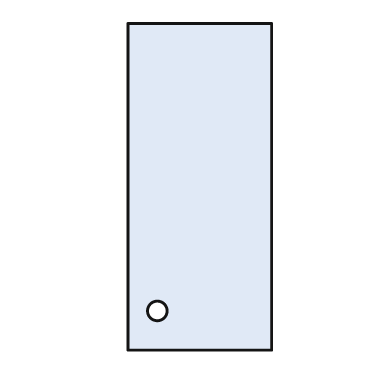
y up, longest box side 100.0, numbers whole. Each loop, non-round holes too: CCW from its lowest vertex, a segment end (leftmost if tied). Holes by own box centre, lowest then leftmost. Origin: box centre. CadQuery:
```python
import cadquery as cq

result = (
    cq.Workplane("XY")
    .moveTo(-22.0, -50.0)
    .lineTo(22.0, -50.0)
    .lineTo(22.0, 50.0)
    .lineTo(-22.0, 50.0)
    .close()
    .moveTo(-13.0, -38.0)
    .circle(3.0)
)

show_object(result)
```